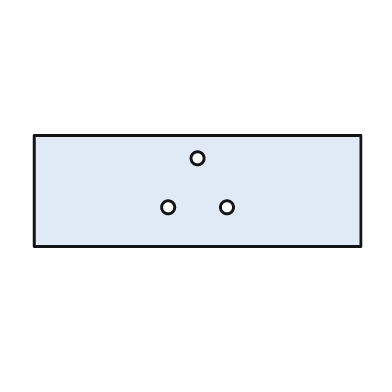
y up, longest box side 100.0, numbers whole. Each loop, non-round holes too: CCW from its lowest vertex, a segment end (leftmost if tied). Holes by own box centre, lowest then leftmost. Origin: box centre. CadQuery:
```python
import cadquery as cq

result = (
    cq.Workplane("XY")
    .moveTo(-50.0, -17.0)
    .lineTo(50.0, -17.0)
    .lineTo(50.0, 17.0)
    .lineTo(-50.0, 17.0)
    .close()
    .moveTo(-9.0, -5.0)
    .circle(2.0)
    .moveTo(9.0, -5.0)
    .circle(2.0)
    .moveTo(0.0, 10.0)
    .circle(2.0)
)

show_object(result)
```